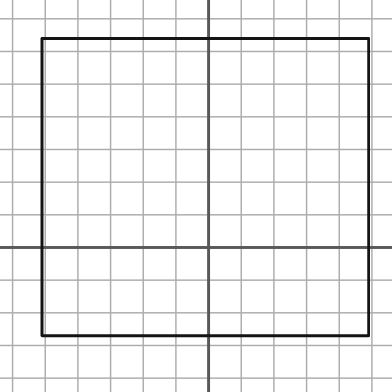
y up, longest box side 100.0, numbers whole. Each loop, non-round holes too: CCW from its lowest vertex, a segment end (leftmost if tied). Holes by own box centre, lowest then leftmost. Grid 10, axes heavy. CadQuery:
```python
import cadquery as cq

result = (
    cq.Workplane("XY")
    .moveTo(-51.0, -27.0)
    .lineTo(49.0, -27.0)
    .lineTo(49.0, 64.0)
    .lineTo(-51.0, 64.0)
    .close()
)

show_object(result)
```